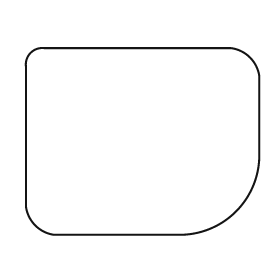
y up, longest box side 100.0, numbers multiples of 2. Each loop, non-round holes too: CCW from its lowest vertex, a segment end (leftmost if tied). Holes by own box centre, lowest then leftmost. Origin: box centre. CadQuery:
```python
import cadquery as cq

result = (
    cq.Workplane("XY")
    .moveTo(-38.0, -40.0)
    .lineTo(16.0, -40.0)
    .threePointArc((40.0, -30.0), (50.0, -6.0))
    .lineTo(50.0, 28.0)
    .threePointArc((46.0, 36.0), (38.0, 40.0))
    .lineTo(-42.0, 40.0)
    .threePointArc((-48.0, 38.0), (-50.0, 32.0))
    .lineTo(-50.0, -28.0)
    .threePointArc((-46.0, -36.0), (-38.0, -40.0))
    .close()
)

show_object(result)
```